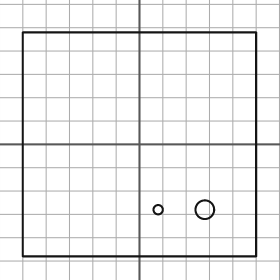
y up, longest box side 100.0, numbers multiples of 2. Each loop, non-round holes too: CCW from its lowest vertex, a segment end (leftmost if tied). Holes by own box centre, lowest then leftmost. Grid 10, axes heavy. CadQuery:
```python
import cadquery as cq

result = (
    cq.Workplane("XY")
    .moveTo(-50.0, -48.0)
    .lineTo(50.0, -48.0)
    .lineTo(50.0, 48.0)
    .lineTo(-50.0, 48.0)
    .close()
    .moveTo(8.0, -28.0)
    .circle(2.0)
    .moveTo(28.0, -28.0)
    .circle(4.0)
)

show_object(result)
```